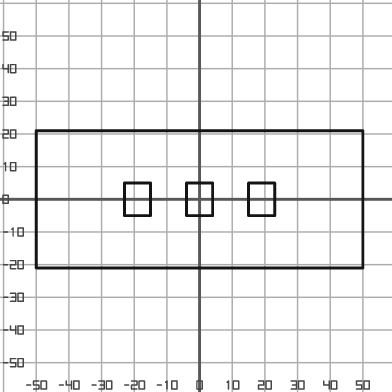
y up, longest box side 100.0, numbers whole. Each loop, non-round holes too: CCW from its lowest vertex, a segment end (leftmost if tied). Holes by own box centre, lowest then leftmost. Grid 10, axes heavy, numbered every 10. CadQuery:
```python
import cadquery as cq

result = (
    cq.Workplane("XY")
    .moveTo(-50.0, -21.0)
    .lineTo(50.0, -21.0)
    .lineTo(50.0, 21.0)
    .lineTo(-50.0, 21.0)
    .close()
    .moveTo(-23.0, -5.0)
    .lineTo(-15.0, -5.0)
    .lineTo(-15.0, 5.0)
    .lineTo(-23.0, 5.0)
    .close()
    .moveTo(-4.0, -5.0)
    .lineTo(4.0, -5.0)
    .lineTo(4.0, 5.0)
    .lineTo(-4.0, 5.0)
    .close()
    .moveTo(15.0, -5.0)
    .lineTo(23.0, -5.0)
    .lineTo(23.0, 5.0)
    .lineTo(15.0, 5.0)
    .close()
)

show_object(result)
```